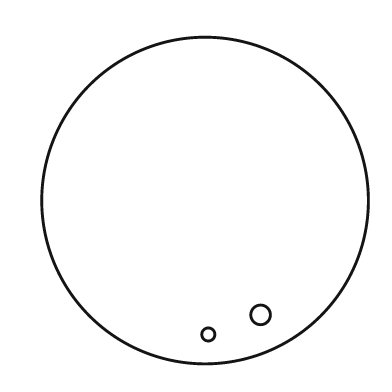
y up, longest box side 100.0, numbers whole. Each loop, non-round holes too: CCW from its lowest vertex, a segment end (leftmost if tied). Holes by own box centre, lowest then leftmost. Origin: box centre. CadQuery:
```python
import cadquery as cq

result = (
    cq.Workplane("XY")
    .moveTo(0.0, 0.0)
    .circle(50.0)
    .moveTo(1.0, -41.0)
    .circle(2.0)
    .moveTo(17.0, -35.0)
    .circle(3.0)
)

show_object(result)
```